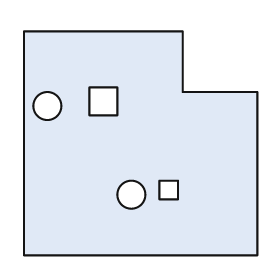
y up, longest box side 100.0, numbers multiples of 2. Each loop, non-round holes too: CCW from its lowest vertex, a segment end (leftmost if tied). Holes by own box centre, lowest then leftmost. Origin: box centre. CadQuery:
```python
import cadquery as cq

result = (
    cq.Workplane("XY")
    .moveTo(-50.0, -48.0)
    .lineTo(50.0, -48.0)
    .lineTo(50.0, 22.0)
    .lineTo(18.0, 22.0)
    .lineTo(18.0, 48.0)
    .lineTo(-50.0, 48.0)
    .close()
    .moveTo(-4.0, -22.0)
    .circle(6.0)
    .moveTo(8.0, -24.0)
    .lineTo(16.0, -24.0)
    .lineTo(16.0, -16.0)
    .lineTo(8.0, -16.0)
    .close()
    .moveTo(-40.0, 16.0)
    .circle(6.0)
    .moveTo(-22.0, 12.0)
    .lineTo(-10.0, 12.0)
    .lineTo(-10.0, 24.0)
    .lineTo(-22.0, 24.0)
    .close()
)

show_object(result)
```